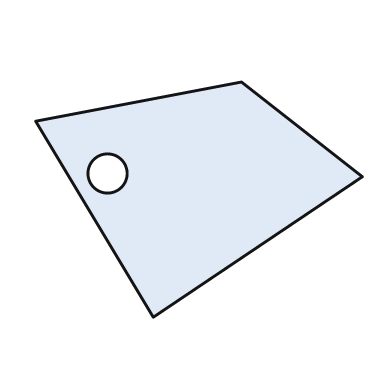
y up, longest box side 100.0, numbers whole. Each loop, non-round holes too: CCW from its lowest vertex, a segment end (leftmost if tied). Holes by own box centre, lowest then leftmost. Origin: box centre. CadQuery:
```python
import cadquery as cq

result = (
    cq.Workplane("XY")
    .moveTo(-14.0, -36.0)
    .lineTo(50.0, 7.0)
    .lineTo(13.0, 36.0)
    .lineTo(-50.0, 24.0)
    .close()
    .moveTo(-28.0, 8.0)
    .circle(6.0)
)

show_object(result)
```